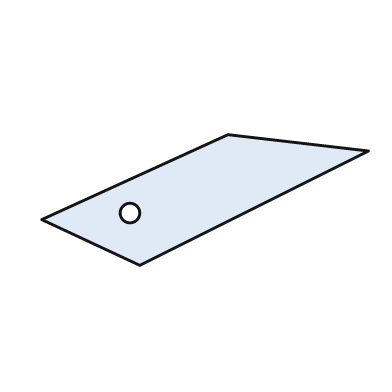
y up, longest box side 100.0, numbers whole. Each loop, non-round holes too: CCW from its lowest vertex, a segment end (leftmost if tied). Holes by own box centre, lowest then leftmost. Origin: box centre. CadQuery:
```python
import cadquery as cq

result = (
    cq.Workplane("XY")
    .moveTo(-20.0, -20.0)
    .lineTo(50.0, 15.0)
    .lineTo(7.0, 20.0)
    .lineTo(-50.0, -6.0)
    .close()
    .moveTo(-23.0, -4.0)
    .circle(3.0)
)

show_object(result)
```